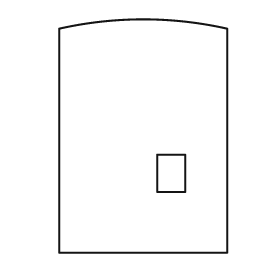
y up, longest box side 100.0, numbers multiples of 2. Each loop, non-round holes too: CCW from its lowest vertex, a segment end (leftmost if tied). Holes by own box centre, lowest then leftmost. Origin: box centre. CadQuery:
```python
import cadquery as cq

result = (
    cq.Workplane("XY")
    .moveTo(-36.0, -50.0)
    .lineTo(36.0, -50.0)
    .lineTo(36.0, 46.0)
    .threePointArc((0.0, 50.0), (-36.0, 46.0))
    .close()
    .moveTo(6.0, -24.0)
    .lineTo(18.0, -24.0)
    .lineTo(18.0, -8.0)
    .lineTo(6.0, -8.0)
    .close()
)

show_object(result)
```